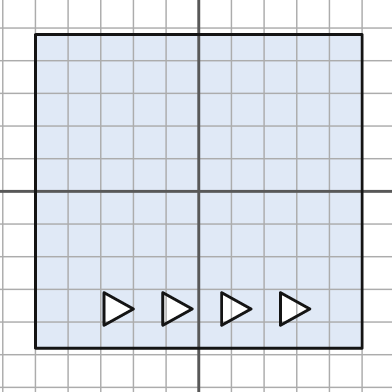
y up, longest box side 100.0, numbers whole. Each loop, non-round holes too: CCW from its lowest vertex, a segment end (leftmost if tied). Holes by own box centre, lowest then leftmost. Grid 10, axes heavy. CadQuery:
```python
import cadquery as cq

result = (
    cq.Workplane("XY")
    .moveTo(-50.0, -48.0)
    .lineTo(50.0, -48.0)
    .lineTo(50.0, 48.0)
    .lineTo(-50.0, 48.0)
    .close()
    .moveTo(-29.0, -41.0)
    .lineTo(-20.0, -36.0)
    .lineTo(-29.0, -31.0)
    .close()
    .moveTo(-11.0, -41.0)
    .lineTo(-2.0, -36.0)
    .lineTo(-11.0, -31.0)
    .close()
    .moveTo(7.0, -41.0)
    .lineTo(16.0, -36.0)
    .lineTo(7.0, -31.0)
    .close()
    .moveTo(25.0, -41.0)
    .lineTo(34.0, -36.0)
    .lineTo(25.0, -31.0)
    .close()
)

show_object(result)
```